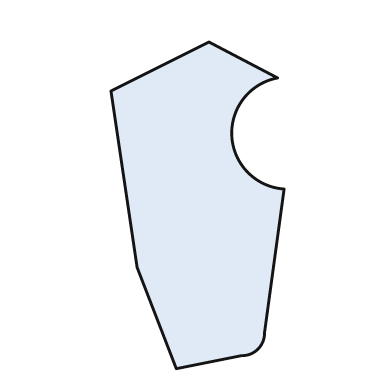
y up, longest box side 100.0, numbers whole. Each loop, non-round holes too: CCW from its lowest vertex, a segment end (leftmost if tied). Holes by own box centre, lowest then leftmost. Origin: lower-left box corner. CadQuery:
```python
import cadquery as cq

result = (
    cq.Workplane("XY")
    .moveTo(20.0, 0.0)
    .lineTo(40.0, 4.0)
    .threePointArc((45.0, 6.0), (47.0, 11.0))
    .lineTo(53.0, 55.0)
    .threePointArc((37.0, 71.0), (51.0, 89.0))
    .lineTo(30.0, 100.0)
    .lineTo(0.0, 85.0)
    .lineTo(8.0, 31.0)
    .close()
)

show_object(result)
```